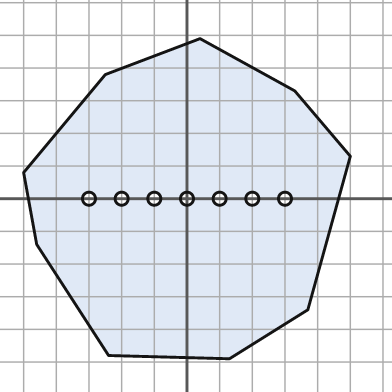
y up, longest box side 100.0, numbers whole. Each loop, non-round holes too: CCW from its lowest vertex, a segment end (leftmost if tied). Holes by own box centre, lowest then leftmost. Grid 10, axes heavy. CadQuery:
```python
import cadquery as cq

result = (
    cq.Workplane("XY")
    .moveTo(13.0, -49.0)
    .lineTo(37.0, -34.0)
    .lineTo(50.0, 13.0)
    .lineTo(33.0, 33.0)
    .lineTo(4.0, 49.0)
    .lineTo(-25.0, 38.0)
    .lineTo(-50.0, 8.0)
    .lineTo(-46.0, -14.0)
    .lineTo(-24.0, -48.0)
    .close()
    .moveTo(-30.0, 0.0)
    .circle(2.0)
    .moveTo(-20.0, 0.0)
    .circle(2.0)
    .moveTo(-10.0, 0.0)
    .circle(2.0)
    .moveTo(0.0, 0.0)
    .circle(2.0)
    .moveTo(10.0, 0.0)
    .circle(2.0)
    .moveTo(20.0, 0.0)
    .circle(2.0)
    .moveTo(30.0, 0.0)
    .circle(2.0)
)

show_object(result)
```